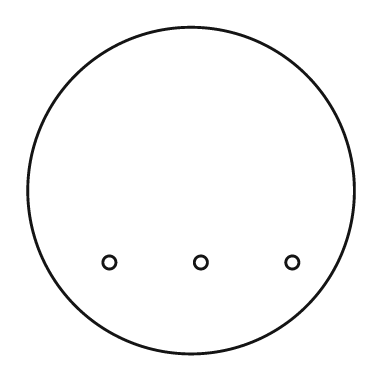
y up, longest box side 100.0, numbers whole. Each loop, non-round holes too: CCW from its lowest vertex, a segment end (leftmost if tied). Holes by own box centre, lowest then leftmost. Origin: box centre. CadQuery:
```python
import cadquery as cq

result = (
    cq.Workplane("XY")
    .moveTo(0.0, 0.0)
    .circle(50.0)
    .moveTo(-25.0, -22.0)
    .circle(2.0)
    .moveTo(3.0, -22.0)
    .circle(2.0)
    .moveTo(31.0, -22.0)
    .circle(2.0)
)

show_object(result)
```